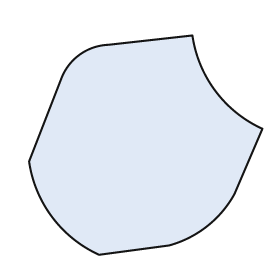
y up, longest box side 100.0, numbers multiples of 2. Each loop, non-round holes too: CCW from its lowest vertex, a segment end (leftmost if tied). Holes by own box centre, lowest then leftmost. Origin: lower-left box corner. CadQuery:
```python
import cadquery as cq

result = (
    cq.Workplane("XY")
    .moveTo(30.0, 0.0)
    .lineTo(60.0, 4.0)
    .threePointArc((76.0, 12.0), (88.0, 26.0))
    .lineTo(100.0, 54.0)
    .threePointArc((80.0, 70.0), (70.0, 94.0))
    .lineTo(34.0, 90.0)
    .threePointArc((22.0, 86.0), (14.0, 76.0))
    .lineTo(0.0, 40.0)
    .threePointArc((10.0, 16.0), (30.0, 0.0))
    .close()
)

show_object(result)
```